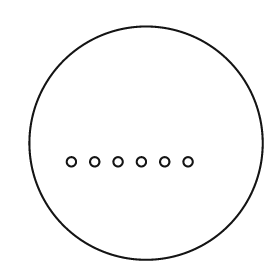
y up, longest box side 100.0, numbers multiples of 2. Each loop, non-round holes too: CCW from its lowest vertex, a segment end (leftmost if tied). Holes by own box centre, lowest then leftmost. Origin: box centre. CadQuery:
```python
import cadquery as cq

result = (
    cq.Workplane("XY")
    .moveTo(0.0, 0.0)
    .circle(50.0)
    .moveTo(-32.0, -8.0)
    .circle(2.0)
    .moveTo(-22.0, -8.0)
    .circle(2.0)
    .moveTo(-12.0, -8.0)
    .circle(2.0)
    .moveTo(-2.0, -8.0)
    .circle(2.0)
    .moveTo(8.0, -8.0)
    .circle(2.0)
    .moveTo(18.0, -8.0)
    .circle(2.0)
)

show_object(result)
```